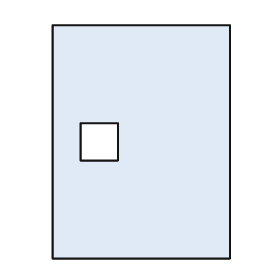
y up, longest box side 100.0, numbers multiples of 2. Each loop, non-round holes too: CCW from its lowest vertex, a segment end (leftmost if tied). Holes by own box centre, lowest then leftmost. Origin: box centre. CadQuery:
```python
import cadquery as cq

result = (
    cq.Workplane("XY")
    .moveTo(-38.0, -50.0)
    .lineTo(38.0, -50.0)
    .lineTo(38.0, 50.0)
    .lineTo(-38.0, 50.0)
    .close()
    .moveTo(-26.0, -8.0)
    .lineTo(-10.0, -8.0)
    .lineTo(-10.0, 8.0)
    .lineTo(-26.0, 8.0)
    .close()
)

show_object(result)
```